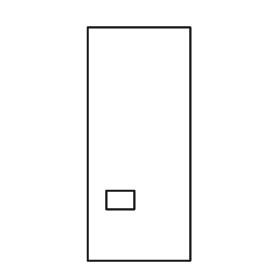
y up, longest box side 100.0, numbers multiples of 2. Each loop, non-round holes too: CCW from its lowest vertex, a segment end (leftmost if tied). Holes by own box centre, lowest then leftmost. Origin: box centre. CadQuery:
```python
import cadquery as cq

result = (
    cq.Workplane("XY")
    .moveTo(-22.0, -50.0)
    .lineTo(22.0, -50.0)
    .lineTo(22.0, 50.0)
    .lineTo(-22.0, 50.0)
    .close()
    .moveTo(-14.0, -28.0)
    .lineTo(-2.0, -28.0)
    .lineTo(-2.0, -20.0)
    .lineTo(-14.0, -20.0)
    .close()
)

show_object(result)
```